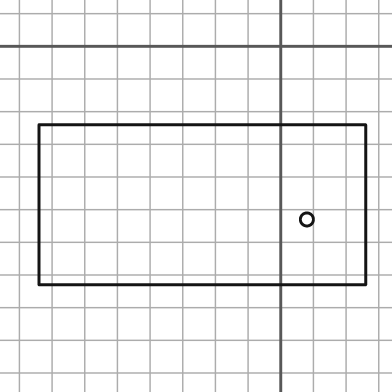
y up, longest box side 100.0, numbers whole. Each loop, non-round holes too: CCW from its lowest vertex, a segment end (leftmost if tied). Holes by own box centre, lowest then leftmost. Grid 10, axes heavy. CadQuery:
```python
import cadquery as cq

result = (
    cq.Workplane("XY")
    .moveTo(-74.0, -73.0)
    .lineTo(26.0, -73.0)
    .lineTo(26.0, -24.0)
    .lineTo(-74.0, -24.0)
    .close()
    .moveTo(8.0, -53.0)
    .circle(2.0)
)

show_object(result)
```